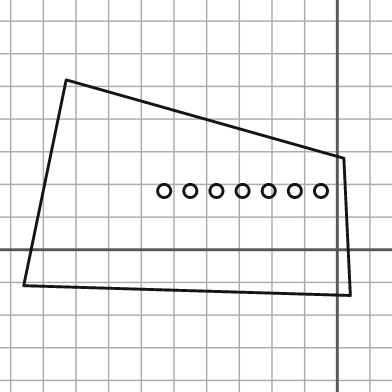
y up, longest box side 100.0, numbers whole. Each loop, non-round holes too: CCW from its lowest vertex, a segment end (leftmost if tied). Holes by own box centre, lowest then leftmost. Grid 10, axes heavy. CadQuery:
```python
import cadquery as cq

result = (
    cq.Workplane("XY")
    .moveTo(4.0, -14.0)
    .lineTo(2.0, 28.0)
    .lineTo(-83.0, 52.0)
    .lineTo(-96.0, -11.0)
    .close()
    .moveTo(-53.0, 18.0)
    .circle(2.0)
    .moveTo(-45.0, 18.0)
    .circle(2.0)
    .moveTo(-37.0, 18.0)
    .circle(2.0)
    .moveTo(-29.0, 18.0)
    .circle(2.0)
    .moveTo(-21.0, 18.0)
    .circle(2.0)
    .moveTo(-13.0, 18.0)
    .circle(2.0)
    .moveTo(-5.0, 18.0)
    .circle(2.0)
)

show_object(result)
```